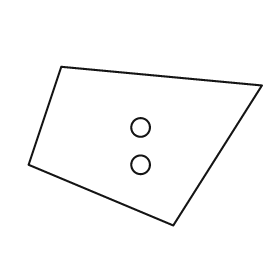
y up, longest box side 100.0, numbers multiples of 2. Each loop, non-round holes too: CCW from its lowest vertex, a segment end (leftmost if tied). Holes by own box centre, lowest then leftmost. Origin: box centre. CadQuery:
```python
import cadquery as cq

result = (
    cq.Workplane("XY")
    .moveTo(12.0, -34.0)
    .lineTo(50.0, 26.0)
    .lineTo(-36.0, 34.0)
    .lineTo(-50.0, -8.0)
    .close()
    .moveTo(-2.0, -8.0)
    .circle(4.0)
    .moveTo(-2.0, 8.0)
    .circle(4.0)
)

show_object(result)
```